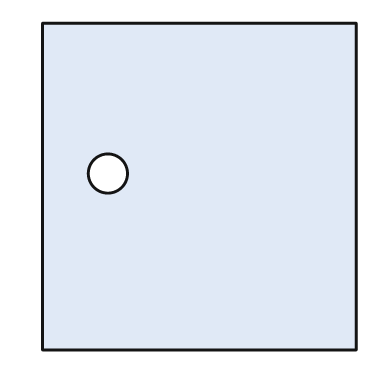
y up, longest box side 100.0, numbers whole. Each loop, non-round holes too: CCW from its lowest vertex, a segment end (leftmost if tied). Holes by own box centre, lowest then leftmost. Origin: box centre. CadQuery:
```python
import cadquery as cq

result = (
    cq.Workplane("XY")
    .moveTo(-48.0, -50.0)
    .lineTo(48.0, -50.0)
    .lineTo(48.0, 50.0)
    .lineTo(-48.0, 50.0)
    .close()
    .moveTo(-28.0, 4.0)
    .circle(6.0)
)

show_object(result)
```